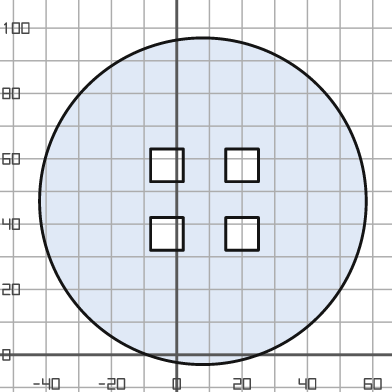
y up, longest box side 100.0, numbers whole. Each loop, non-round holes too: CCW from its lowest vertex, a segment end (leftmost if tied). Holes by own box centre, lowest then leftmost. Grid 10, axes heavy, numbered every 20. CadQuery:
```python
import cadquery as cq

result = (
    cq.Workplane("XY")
    .moveTo(8.0, 47.0)
    .circle(50.0)
    .moveTo(-8.0, 32.0)
    .lineTo(2.0, 32.0)
    .lineTo(2.0, 42.0)
    .lineTo(-8.0, 42.0)
    .close()
    .moveTo(15.0, 32.0)
    .lineTo(25.0, 32.0)
    .lineTo(25.0, 42.0)
    .lineTo(15.0, 42.0)
    .close()
    .moveTo(-8.0, 53.0)
    .lineTo(2.0, 53.0)
    .lineTo(2.0, 63.0)
    .lineTo(-8.0, 63.0)
    .close()
    .moveTo(15.0, 53.0)
    .lineTo(25.0, 53.0)
    .lineTo(25.0, 63.0)
    .lineTo(15.0, 63.0)
    .close()
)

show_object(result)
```